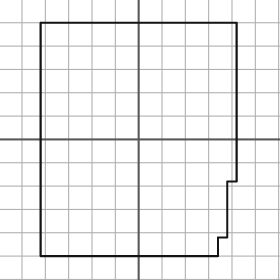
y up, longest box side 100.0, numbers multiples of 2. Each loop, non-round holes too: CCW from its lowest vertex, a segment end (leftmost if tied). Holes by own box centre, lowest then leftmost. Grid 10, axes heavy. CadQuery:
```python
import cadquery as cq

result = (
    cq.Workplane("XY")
    .moveTo(-42.0, -50.0)
    .lineTo(34.0, -50.0)
    .lineTo(34.0, -42.0)
    .lineTo(38.0, -42.0)
    .lineTo(38.0, -18.0)
    .lineTo(42.0, -18.0)
    .lineTo(42.0, 50.0)
    .lineTo(-42.0, 50.0)
    .close()
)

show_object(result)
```